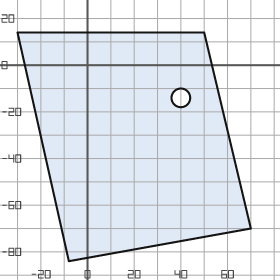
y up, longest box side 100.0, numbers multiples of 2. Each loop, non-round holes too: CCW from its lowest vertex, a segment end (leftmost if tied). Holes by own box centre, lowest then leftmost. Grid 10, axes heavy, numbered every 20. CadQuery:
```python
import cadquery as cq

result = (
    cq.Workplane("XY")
    .moveTo(-8.0, -84.0)
    .lineTo(70.0, -70.0)
    .lineTo(50.0, 14.0)
    .lineTo(-30.0, 14.0)
    .close()
    .moveTo(40.0, -14.0)
    .circle(4.0)
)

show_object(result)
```